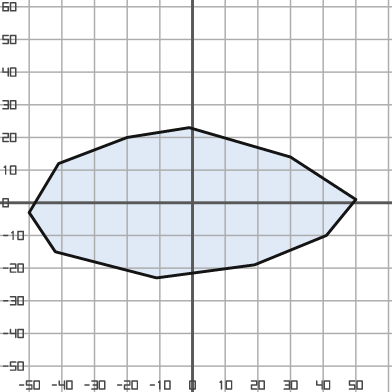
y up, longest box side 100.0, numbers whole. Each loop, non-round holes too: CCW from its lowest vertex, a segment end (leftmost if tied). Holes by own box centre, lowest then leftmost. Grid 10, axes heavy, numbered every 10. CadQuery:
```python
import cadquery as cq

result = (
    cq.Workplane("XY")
    .moveTo(-11.0, -23.0)
    .lineTo(19.0, -19.0)
    .lineTo(41.0, -10.0)
    .lineTo(50.0, 1.0)
    .lineTo(30.0, 14.0)
    .lineTo(-1.0, 23.0)
    .lineTo(-20.0, 20.0)
    .lineTo(-41.0, 12.0)
    .lineTo(-50.0, -3.0)
    .lineTo(-42.0, -15.0)
    .close()
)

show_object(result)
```